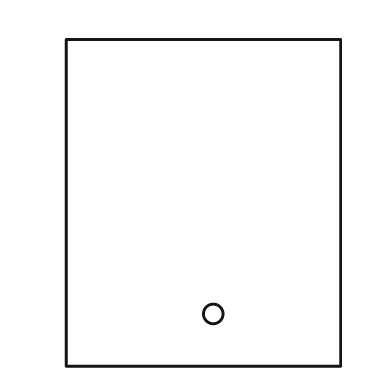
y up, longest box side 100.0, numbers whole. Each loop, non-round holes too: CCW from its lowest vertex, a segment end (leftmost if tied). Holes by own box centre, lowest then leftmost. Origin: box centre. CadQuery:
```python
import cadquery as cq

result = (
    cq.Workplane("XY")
    .moveTo(-42.0, -50.0)
    .lineTo(42.0, -50.0)
    .lineTo(42.0, 50.0)
    .lineTo(-42.0, 50.0)
    .close()
    .moveTo(3.0, -34.0)
    .circle(3.0)
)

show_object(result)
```